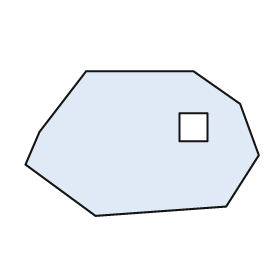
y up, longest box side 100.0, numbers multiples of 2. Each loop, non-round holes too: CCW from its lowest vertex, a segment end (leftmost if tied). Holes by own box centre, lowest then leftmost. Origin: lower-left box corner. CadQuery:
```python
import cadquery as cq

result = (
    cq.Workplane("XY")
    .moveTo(30.0, 0.0)
    .lineTo(86.0, 4.0)
    .lineTo(100.0, 26.0)
    .lineTo(92.0, 48.0)
    .lineTo(72.0, 62.0)
    .lineTo(26.0, 62.0)
    .lineTo(6.0, 36.0)
    .lineTo(0.0, 22.0)
    .close()
    .moveTo(66.0, 32.0)
    .lineTo(78.0, 32.0)
    .lineTo(78.0, 44.0)
    .lineTo(66.0, 44.0)
    .close()
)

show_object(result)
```